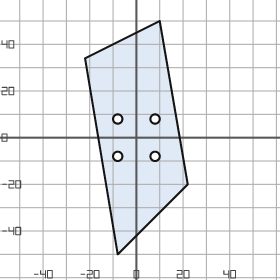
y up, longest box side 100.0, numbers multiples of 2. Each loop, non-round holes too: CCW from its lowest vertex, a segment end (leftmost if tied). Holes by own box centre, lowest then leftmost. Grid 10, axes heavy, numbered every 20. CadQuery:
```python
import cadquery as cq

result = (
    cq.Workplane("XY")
    .moveTo(-8.0, -50.0)
    .lineTo(22.0, -20.0)
    .lineTo(10.0, 50.0)
    .lineTo(-22.0, 34.0)
    .close()
    .moveTo(-8.0, -8.0)
    .circle(2.0)
    .moveTo(8.0, -8.0)
    .circle(2.0)
    .moveTo(-8.0, 8.0)
    .circle(2.0)
    .moveTo(8.0, 8.0)
    .circle(2.0)
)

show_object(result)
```